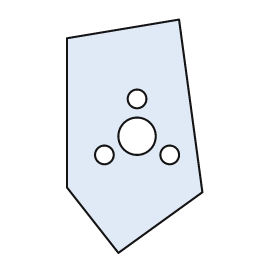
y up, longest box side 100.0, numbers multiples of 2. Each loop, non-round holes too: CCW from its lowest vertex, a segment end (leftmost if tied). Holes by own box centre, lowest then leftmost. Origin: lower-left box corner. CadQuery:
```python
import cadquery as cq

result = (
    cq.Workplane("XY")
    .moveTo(22.0, 0.0)
    .lineTo(58.0, 26.0)
    .lineTo(48.0, 100.0)
    .lineTo(0.0, 92.0)
    .lineTo(0.0, 28.0)
    .close()
    .moveTo(16.0, 42.0)
    .circle(4.0)
    .moveTo(44.0, 42.0)
    .circle(4.0)
    .moveTo(30.0, 50.0)
    .circle(8.0)
    .moveTo(30.0, 66.0)
    .circle(4.0)
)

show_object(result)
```